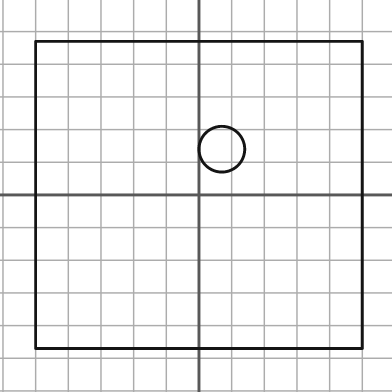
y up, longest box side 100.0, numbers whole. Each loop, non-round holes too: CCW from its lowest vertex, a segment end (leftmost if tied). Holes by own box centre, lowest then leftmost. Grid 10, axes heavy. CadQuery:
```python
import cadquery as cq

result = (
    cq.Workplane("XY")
    .moveTo(-50.0, -47.0)
    .lineTo(50.0, -47.0)
    .lineTo(50.0, 47.0)
    .lineTo(-50.0, 47.0)
    .close()
    .moveTo(7.0, 14.0)
    .circle(7.0)
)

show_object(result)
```